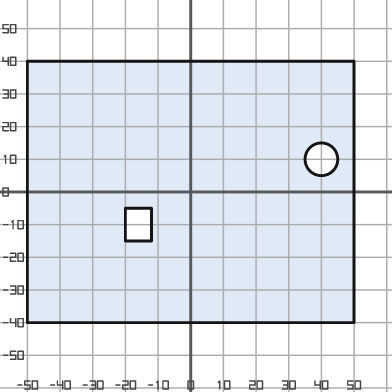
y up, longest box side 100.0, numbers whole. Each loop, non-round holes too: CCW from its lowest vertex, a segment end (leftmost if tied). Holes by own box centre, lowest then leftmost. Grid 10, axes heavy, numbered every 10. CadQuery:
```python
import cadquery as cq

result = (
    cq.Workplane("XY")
    .moveTo(-50.0, -40.0)
    .lineTo(50.0, -40.0)
    .lineTo(50.0, 40.0)
    .lineTo(-50.0, 40.0)
    .close()
    .moveTo(-20.0, -15.0)
    .lineTo(-12.0, -15.0)
    .lineTo(-12.0, -5.0)
    .lineTo(-20.0, -5.0)
    .close()
    .moveTo(40.0, 10.0)
    .circle(5.0)
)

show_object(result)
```